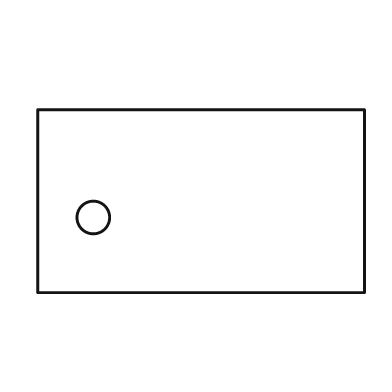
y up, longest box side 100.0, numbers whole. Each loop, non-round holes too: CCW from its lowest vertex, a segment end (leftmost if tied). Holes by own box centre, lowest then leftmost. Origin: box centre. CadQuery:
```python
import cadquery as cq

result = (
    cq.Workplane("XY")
    .moveTo(-50.0, -28.0)
    .lineTo(50.0, -28.0)
    .lineTo(50.0, 28.0)
    .lineTo(-50.0, 28.0)
    .close()
    .moveTo(-33.0, -5.0)
    .circle(5.0)
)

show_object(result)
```